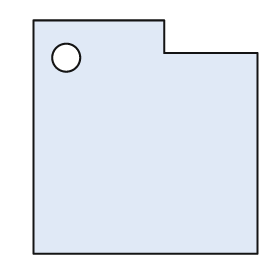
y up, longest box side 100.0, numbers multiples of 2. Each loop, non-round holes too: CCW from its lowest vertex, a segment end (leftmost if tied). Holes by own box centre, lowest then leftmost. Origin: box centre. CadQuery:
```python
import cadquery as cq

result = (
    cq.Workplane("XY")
    .moveTo(-48.0, -50.0)
    .lineTo(48.0, -50.0)
    .lineTo(48.0, 36.0)
    .lineTo(8.0, 36.0)
    .lineTo(8.0, 50.0)
    .lineTo(-48.0, 50.0)
    .close()
    .moveTo(-34.0, 34.0)
    .circle(6.0)
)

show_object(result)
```